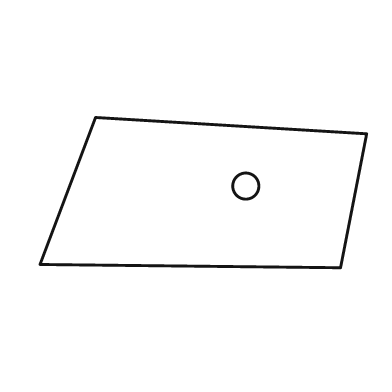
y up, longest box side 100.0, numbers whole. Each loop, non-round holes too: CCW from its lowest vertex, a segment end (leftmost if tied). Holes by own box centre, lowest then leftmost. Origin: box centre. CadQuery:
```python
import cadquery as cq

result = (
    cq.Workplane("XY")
    .moveTo(42.0, -23.0)
    .lineTo(50.0, 18.0)
    .lineTo(-33.0, 23.0)
    .lineTo(-50.0, -22.0)
    .close()
    .moveTo(13.0, 2.0)
    .circle(4.0)
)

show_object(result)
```